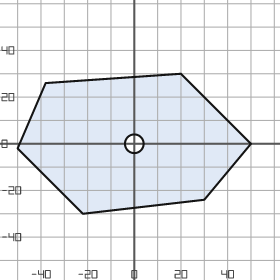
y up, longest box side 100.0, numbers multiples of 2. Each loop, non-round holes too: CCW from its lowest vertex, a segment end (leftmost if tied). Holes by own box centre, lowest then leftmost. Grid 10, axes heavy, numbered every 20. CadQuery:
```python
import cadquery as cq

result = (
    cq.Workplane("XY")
    .moveTo(-22.0, -30.0)
    .lineTo(30.0, -24.0)
    .lineTo(50.0, 0.0)
    .lineTo(20.0, 30.0)
    .lineTo(-38.0, 26.0)
    .lineTo(-50.0, -2.0)
    .close()
    .moveTo(0.0, 0.0)
    .circle(4.0)
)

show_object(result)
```